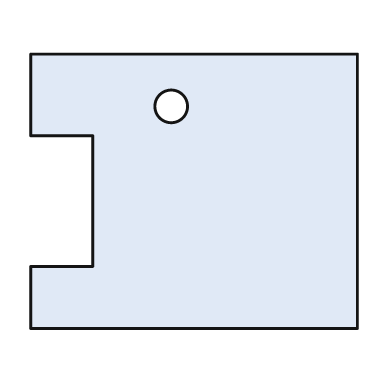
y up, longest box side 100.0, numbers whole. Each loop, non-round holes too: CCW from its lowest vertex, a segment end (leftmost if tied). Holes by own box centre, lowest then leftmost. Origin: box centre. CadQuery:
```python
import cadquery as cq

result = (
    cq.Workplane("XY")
    .moveTo(-50.0, -42.0)
    .lineTo(50.0, -42.0)
    .lineTo(50.0, 42.0)
    .lineTo(-50.0, 42.0)
    .lineTo(-50.0, 17.0)
    .lineTo(-31.0, 17.0)
    .lineTo(-31.0, -23.0)
    .lineTo(-50.0, -23.0)
    .close()
    .moveTo(-7.0, 26.0)
    .circle(5.0)
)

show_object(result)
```